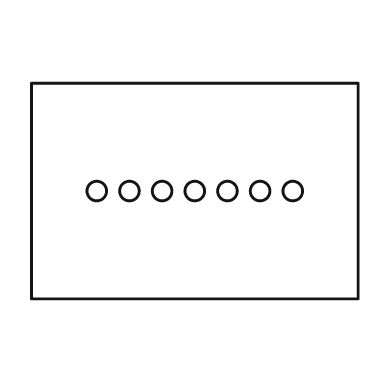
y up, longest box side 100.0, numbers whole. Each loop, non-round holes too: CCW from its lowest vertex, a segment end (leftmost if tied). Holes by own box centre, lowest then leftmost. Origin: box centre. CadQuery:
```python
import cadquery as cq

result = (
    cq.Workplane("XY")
    .moveTo(-50.0, -33.0)
    .lineTo(50.0, -33.0)
    .lineTo(50.0, 33.0)
    .lineTo(-50.0, 33.0)
    .close()
    .moveTo(-30.0, 0.0)
    .circle(3.0)
    .moveTo(-20.0, 0.0)
    .circle(3.0)
    .moveTo(-10.0, 0.0)
    .circle(3.0)
    .moveTo(0.0, 0.0)
    .circle(3.0)
    .moveTo(10.0, 0.0)
    .circle(3.0)
    .moveTo(20.0, 0.0)
    .circle(3.0)
    .moveTo(30.0, 0.0)
    .circle(3.0)
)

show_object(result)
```